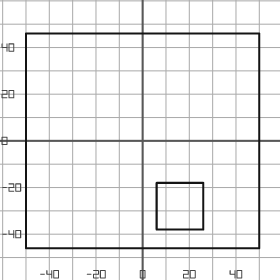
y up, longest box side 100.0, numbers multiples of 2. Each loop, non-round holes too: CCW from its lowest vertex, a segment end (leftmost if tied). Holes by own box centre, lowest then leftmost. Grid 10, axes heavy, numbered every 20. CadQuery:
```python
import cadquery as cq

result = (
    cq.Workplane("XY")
    .moveTo(-50.0, -46.0)
    .lineTo(50.0, -46.0)
    .lineTo(50.0, 46.0)
    .lineTo(-50.0, 46.0)
    .close()
    .moveTo(6.0, -38.0)
    .lineTo(26.0, -38.0)
    .lineTo(26.0, -18.0)
    .lineTo(6.0, -18.0)
    .close()
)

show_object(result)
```